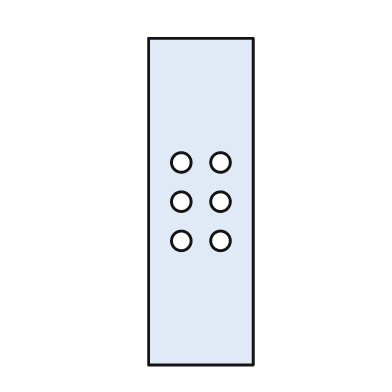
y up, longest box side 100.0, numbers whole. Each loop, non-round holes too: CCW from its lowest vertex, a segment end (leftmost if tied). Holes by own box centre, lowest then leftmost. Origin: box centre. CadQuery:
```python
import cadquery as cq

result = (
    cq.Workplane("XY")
    .moveTo(-16.0, -50.0)
    .lineTo(16.0, -50.0)
    .lineTo(16.0, 50.0)
    .lineTo(-16.0, 50.0)
    .close()
    .moveTo(-6.0, -12.0)
    .circle(3.0)
    .moveTo(6.0, -12.0)
    .circle(3.0)
    .moveTo(-6.0, 0.0)
    .circle(3.0)
    .moveTo(6.0, 0.0)
    .circle(3.0)
    .moveTo(-6.0, 12.0)
    .circle(3.0)
    .moveTo(6.0, 12.0)
    .circle(3.0)
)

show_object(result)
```